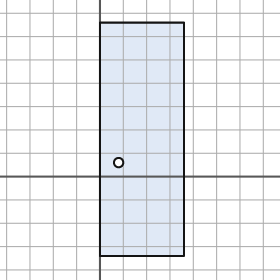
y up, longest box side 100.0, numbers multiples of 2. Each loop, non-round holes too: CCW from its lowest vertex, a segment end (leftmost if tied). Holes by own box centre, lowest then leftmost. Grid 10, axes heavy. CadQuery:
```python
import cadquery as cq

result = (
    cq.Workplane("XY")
    .moveTo(0.0, -34.0)
    .lineTo(36.0, -34.0)
    .lineTo(36.0, 66.0)
    .lineTo(0.0, 66.0)
    .close()
    .moveTo(8.0, 6.0)
    .circle(2.0)
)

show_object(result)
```